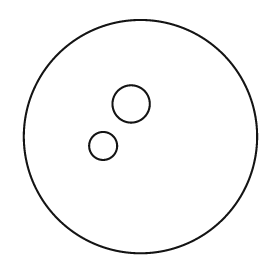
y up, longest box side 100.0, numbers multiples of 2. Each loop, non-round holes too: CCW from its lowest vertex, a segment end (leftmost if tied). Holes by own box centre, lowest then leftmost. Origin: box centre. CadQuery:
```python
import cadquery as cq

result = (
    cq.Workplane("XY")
    .moveTo(0.0, 0.0)
    .circle(50.0)
    .moveTo(-16.0, -4.0)
    .circle(6.0)
    .moveTo(-4.0, 14.0)
    .circle(8.0)
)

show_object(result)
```